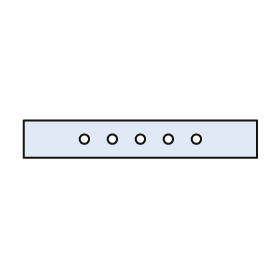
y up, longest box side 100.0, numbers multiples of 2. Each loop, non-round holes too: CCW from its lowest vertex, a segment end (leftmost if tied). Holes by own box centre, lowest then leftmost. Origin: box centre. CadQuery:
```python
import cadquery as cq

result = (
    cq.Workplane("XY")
    .moveTo(-50.0, -8.0)
    .lineTo(50.0, -8.0)
    .lineTo(50.0, 8.0)
    .lineTo(-50.0, 8.0)
    .close()
    .moveTo(-24.0, 0.0)
    .circle(2.0)
    .moveTo(-12.0, 0.0)
    .circle(2.0)
    .moveTo(0.0, 0.0)
    .circle(2.0)
    .moveTo(12.0, 0.0)
    .circle(2.0)
    .moveTo(24.0, 0.0)
    .circle(2.0)
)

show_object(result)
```